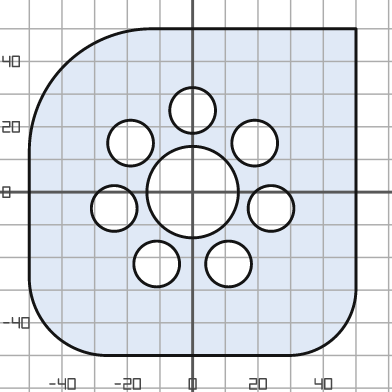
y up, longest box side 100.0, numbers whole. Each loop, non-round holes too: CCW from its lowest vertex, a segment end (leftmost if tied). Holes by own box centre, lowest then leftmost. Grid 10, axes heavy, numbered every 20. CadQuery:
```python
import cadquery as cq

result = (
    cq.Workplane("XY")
    .moveTo(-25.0, -50.0)
    .lineTo(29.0, -50.0)
    .threePointArc((44.0, -44.0), (50.0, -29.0))
    .lineTo(50.0, 50.0)
    .lineTo(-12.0, 50.0)
    .threePointArc((-39.0, 39.0), (-50.0, 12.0))
    .lineTo(-50.0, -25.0)
    .threePointArc((-43.0, -43.0), (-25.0, -50.0))
    .close()
    .moveTo(-11.0, -22.0)
    .circle(7.0)
    .moveTo(11.0, -22.0)
    .circle(7.0)
    .moveTo(-24.0, -5.0)
    .circle(7.0)
    .moveTo(24.0, -5.0)
    .circle(7.0)
    .moveTo(0.0, 0.0)
    .circle(14.0)
    .moveTo(-19.0, 15.0)
    .circle(7.0)
    .moveTo(19.0, 15.0)
    .circle(7.0)
    .moveTo(0.0, 25.0)
    .circle(7.0)
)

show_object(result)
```